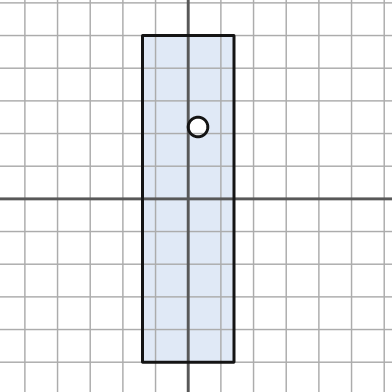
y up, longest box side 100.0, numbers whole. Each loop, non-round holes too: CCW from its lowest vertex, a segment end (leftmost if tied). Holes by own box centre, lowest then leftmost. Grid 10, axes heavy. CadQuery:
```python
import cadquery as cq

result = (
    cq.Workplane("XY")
    .moveTo(-14.0, -50.0)
    .lineTo(14.0, -50.0)
    .lineTo(14.0, 50.0)
    .lineTo(-14.0, 50.0)
    .close()
    .moveTo(3.0, 22.0)
    .circle(3.0)
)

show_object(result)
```